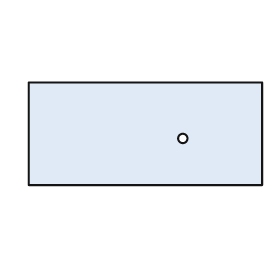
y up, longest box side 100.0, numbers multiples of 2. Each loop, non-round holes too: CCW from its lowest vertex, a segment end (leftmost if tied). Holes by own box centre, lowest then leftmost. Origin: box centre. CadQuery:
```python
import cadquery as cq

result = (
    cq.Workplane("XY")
    .moveTo(-50.0, -22.0)
    .lineTo(50.0, -22.0)
    .lineTo(50.0, 22.0)
    .lineTo(-50.0, 22.0)
    .close()
    .moveTo(16.0, -2.0)
    .circle(2.0)
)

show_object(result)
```